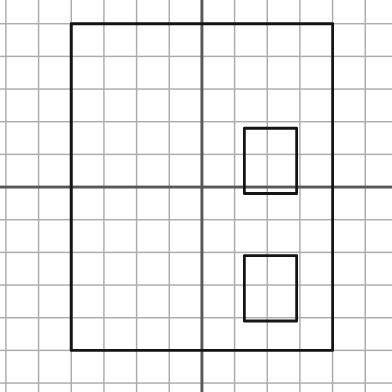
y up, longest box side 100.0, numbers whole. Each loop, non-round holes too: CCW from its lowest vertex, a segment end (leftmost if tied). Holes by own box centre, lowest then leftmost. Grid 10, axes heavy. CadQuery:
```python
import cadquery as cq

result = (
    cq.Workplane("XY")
    .moveTo(-40.0, -50.0)
    .lineTo(40.0, -50.0)
    .lineTo(40.0, 50.0)
    .lineTo(-40.0, 50.0)
    .close()
    .moveTo(13.0, -41.0)
    .lineTo(29.0, -41.0)
    .lineTo(29.0, -21.0)
    .lineTo(13.0, -21.0)
    .close()
    .moveTo(13.0, -2.0)
    .lineTo(29.0, -2.0)
    .lineTo(29.0, 18.0)
    .lineTo(13.0, 18.0)
    .close()
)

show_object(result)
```